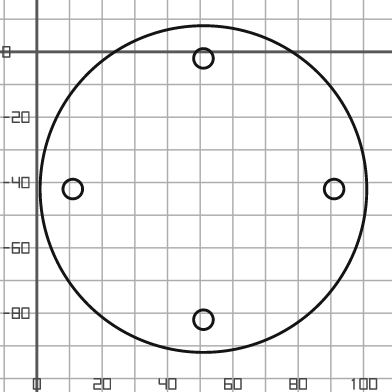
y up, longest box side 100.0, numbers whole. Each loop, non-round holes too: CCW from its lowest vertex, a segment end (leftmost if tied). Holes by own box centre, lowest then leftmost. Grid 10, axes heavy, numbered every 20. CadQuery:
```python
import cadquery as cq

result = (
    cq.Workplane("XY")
    .moveTo(51.0, -42.0)
    .circle(50.0)
    .moveTo(51.0, -82.0)
    .circle(3.0)
    .moveTo(11.0, -42.0)
    .circle(3.0)
    .moveTo(91.0, -42.0)
    .circle(3.0)
    .moveTo(51.0, -2.0)
    .circle(3.0)
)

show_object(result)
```